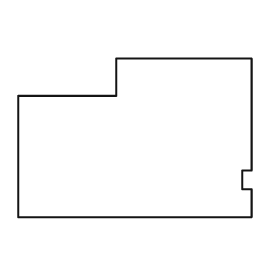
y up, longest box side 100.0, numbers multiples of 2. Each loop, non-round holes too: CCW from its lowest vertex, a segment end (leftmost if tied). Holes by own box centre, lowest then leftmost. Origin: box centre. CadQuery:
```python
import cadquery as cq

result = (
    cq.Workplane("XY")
    .moveTo(-50.0, -34.0)
    .lineTo(50.0, -34.0)
    .lineTo(50.0, -22.0)
    .lineTo(46.0, -22.0)
    .lineTo(46.0, -14.0)
    .lineTo(50.0, -14.0)
    .lineTo(50.0, 34.0)
    .lineTo(-8.0, 34.0)
    .lineTo(-8.0, 18.0)
    .lineTo(-50.0, 18.0)
    .close()
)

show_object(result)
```